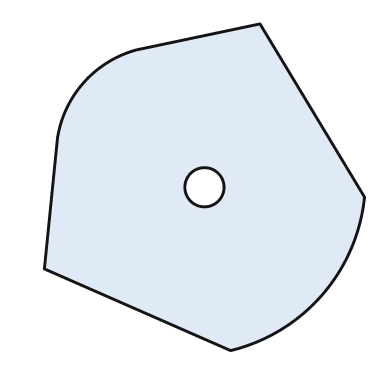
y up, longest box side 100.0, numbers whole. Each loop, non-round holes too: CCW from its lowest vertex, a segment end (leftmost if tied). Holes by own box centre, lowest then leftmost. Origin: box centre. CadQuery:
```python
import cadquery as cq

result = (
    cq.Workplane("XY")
    .moveTo(8.0, -50.0)
    .threePointArc((36.0, -33.0), (49.0, -3.0))
    .lineTo(17.0, 50.0)
    .lineTo(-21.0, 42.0)
    .threePointArc((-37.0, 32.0), (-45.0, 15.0))
    .lineTo(-49.0, -25.0)
    .close()
    .moveTo(0.0, 0.0)
    .circle(6.0)
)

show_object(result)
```